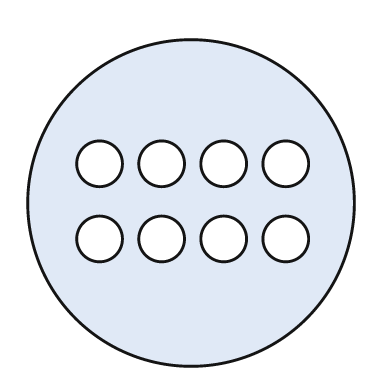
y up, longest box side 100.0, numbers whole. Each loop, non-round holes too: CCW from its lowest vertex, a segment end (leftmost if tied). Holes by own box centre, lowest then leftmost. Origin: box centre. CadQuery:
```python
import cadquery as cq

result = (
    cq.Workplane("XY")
    .moveTo(0.0, 0.0)
    .circle(50.0)
    .moveTo(-28.0, -11.0)
    .circle(7.0)
    .moveTo(-9.0, -11.0)
    .circle(7.0)
    .moveTo(10.0, -11.0)
    .circle(7.0)
    .moveTo(29.0, -11.0)
    .circle(7.0)
    .moveTo(-28.0, 12.0)
    .circle(7.0)
    .moveTo(-9.0, 12.0)
    .circle(7.0)
    .moveTo(10.0, 12.0)
    .circle(7.0)
    .moveTo(29.0, 12.0)
    .circle(7.0)
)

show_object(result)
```